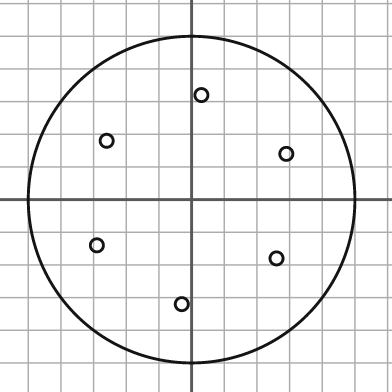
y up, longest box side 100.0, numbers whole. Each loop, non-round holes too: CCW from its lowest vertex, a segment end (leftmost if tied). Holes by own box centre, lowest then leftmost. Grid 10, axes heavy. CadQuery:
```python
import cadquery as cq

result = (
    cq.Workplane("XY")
    .moveTo(0.0, 0.0)
    .circle(50.0)
    .moveTo(-3.0, -32.0)
    .circle(2.0)
    .moveTo(26.0, -18.0)
    .circle(2.0)
    .moveTo(-29.0, -14.0)
    .circle(2.0)
    .moveTo(29.0, 14.0)
    .circle(2.0)
    .moveTo(-26.0, 18.0)
    .circle(2.0)
    .moveTo(3.0, 32.0)
    .circle(2.0)
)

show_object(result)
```